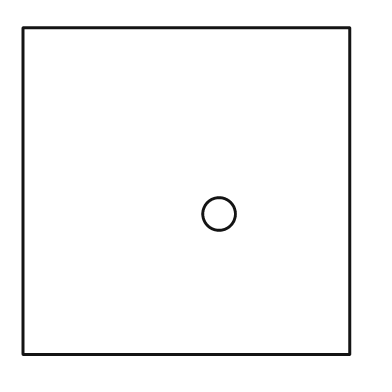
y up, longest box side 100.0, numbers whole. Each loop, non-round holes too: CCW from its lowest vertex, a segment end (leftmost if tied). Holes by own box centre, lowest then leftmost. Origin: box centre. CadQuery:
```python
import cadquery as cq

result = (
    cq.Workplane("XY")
    .moveTo(-50.0, -50.0)
    .lineTo(50.0, -50.0)
    .lineTo(50.0, 50.0)
    .lineTo(-50.0, 50.0)
    .close()
    .moveTo(10.0, -7.0)
    .circle(5.0)
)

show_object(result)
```